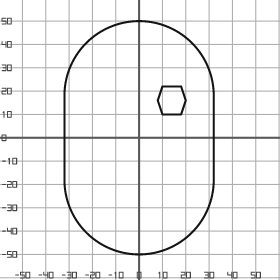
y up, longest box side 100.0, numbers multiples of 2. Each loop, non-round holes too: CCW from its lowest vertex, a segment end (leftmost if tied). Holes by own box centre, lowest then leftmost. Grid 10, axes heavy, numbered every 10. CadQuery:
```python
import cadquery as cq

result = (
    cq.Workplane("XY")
    .moveTo(-32.0, -18.0)
    .threePointArc((0.0, -50.0), (32.0, -18.0))
    .lineTo(32.0, 18.0)
    .threePointArc((0.0, 50.0), (-32.0, 18.0))
    .close()
    .moveTo(10.0, 10.0)
    .lineTo(18.0, 10.0)
    .lineTo(20.0, 16.0)
    .lineTo(18.0, 22.0)
    .lineTo(10.0, 22.0)
    .lineTo(8.0, 16.0)
    .close()
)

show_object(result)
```